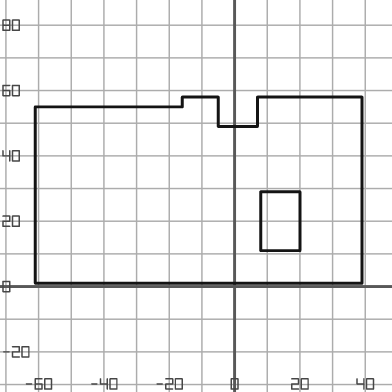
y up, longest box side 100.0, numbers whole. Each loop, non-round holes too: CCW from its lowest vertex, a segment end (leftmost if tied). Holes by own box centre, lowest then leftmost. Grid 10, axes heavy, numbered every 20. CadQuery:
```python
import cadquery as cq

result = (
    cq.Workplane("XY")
    .moveTo(-61.0, 1.0)
    .lineTo(39.0, 1.0)
    .lineTo(39.0, 58.0)
    .lineTo(7.0, 58.0)
    .lineTo(7.0, 49.0)
    .lineTo(-5.0, 49.0)
    .lineTo(-5.0, 58.0)
    .lineTo(-16.0, 58.0)
    .lineTo(-16.0, 55.0)
    .lineTo(-61.0, 55.0)
    .close()
    .moveTo(8.0, 11.0)
    .lineTo(20.0, 11.0)
    .lineTo(20.0, 29.0)
    .lineTo(8.0, 29.0)
    .close()
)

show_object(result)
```